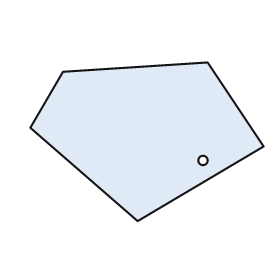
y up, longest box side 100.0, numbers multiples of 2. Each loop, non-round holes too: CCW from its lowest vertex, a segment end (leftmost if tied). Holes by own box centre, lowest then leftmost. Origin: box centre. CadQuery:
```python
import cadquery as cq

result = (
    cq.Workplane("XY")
    .moveTo(-4.0, -34.0)
    .lineTo(50.0, -2.0)
    .lineTo(26.0, 34.0)
    .lineTo(-36.0, 30.0)
    .lineTo(-50.0, 6.0)
    .close()
    .moveTo(24.0, -8.0)
    .circle(2.0)
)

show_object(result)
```